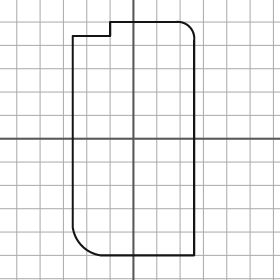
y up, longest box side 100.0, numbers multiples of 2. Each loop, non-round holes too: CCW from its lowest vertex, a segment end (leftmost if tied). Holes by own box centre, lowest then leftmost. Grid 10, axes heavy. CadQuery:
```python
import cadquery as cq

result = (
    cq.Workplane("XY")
    .moveTo(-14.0, -50.0)
    .lineTo(26.0, -50.0)
    .lineTo(26.0, 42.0)
    .threePointArc((24.0, 48.0), (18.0, 50.0))
    .lineTo(-10.0, 50.0)
    .lineTo(-10.0, 44.0)
    .lineTo(-26.0, 44.0)
    .lineTo(-26.0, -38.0)
    .threePointArc((-22.0, -46.0), (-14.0, -50.0))
    .close()
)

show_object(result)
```